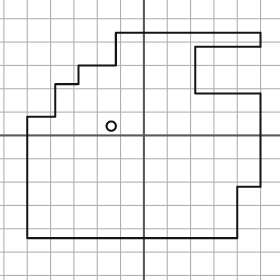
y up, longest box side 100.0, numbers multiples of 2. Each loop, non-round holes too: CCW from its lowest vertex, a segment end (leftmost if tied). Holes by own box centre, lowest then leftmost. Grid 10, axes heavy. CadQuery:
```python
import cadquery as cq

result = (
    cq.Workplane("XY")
    .moveTo(-50.0, -44.0)
    .lineTo(40.0, -44.0)
    .lineTo(40.0, -22.0)
    .lineTo(50.0, -22.0)
    .lineTo(50.0, 18.0)
    .lineTo(22.0, 18.0)
    .lineTo(22.0, 38.0)
    .lineTo(50.0, 38.0)
    .lineTo(50.0, 44.0)
    .lineTo(-12.0, 44.0)
    .lineTo(-12.0, 30.0)
    .lineTo(-28.0, 30.0)
    .lineTo(-28.0, 22.0)
    .lineTo(-38.0, 22.0)
    .lineTo(-38.0, 8.0)
    .lineTo(-50.0, 8.0)
    .close()
    .moveTo(-14.0, 4.0)
    .circle(2.0)
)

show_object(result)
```